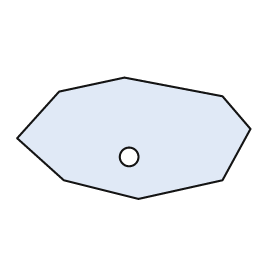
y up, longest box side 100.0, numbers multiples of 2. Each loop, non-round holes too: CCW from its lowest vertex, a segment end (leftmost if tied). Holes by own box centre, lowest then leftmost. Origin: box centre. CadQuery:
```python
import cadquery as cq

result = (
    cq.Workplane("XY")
    .moveTo(2.0, -26.0)
    .lineTo(38.0, -18.0)
    .lineTo(50.0, 4.0)
    .lineTo(38.0, 18.0)
    .lineTo(-4.0, 26.0)
    .lineTo(-32.0, 20.0)
    .lineTo(-50.0, 0.0)
    .lineTo(-30.0, -18.0)
    .close()
    .moveTo(-2.0, -8.0)
    .circle(4.0)
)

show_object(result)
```